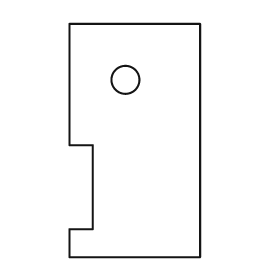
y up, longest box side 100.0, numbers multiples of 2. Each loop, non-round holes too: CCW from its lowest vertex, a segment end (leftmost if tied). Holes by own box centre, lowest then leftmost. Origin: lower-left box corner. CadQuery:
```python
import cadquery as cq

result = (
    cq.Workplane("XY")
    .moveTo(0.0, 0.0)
    .lineTo(56.0, 0.0)
    .lineTo(56.0, 100.0)
    .lineTo(0.0, 100.0)
    .lineTo(0.0, 48.0)
    .lineTo(10.0, 48.0)
    .lineTo(10.0, 12.0)
    .lineTo(0.0, 12.0)
    .close()
    .moveTo(24.0, 76.0)
    .circle(6.0)
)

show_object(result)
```